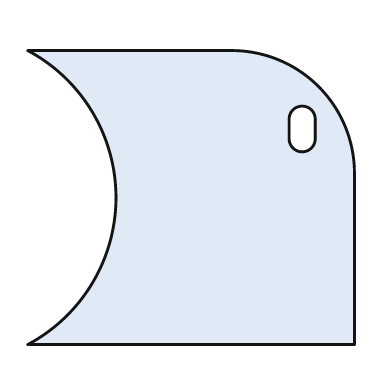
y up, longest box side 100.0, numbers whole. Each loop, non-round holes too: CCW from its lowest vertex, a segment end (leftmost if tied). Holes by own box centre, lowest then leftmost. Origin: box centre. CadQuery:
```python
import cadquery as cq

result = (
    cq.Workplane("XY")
    .moveTo(-50.0, -45.0)
    .lineTo(50.0, -45.0)
    .lineTo(50.0, 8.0)
    .threePointArc((39.0, 34.0), (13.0, 45.0))
    .lineTo(-50.0, 45.0)
    .threePointArc((-23.0, 0.0), (-50.0, -45.0))
    .close()
    .moveTo(30.0, 18.0)
    .threePointArc((34.0, 14.0), (38.0, 18.0))
    .lineTo(38.0, 24.0)
    .threePointArc((34.0, 28.0), (30.0, 24.0))
    .close()
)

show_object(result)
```